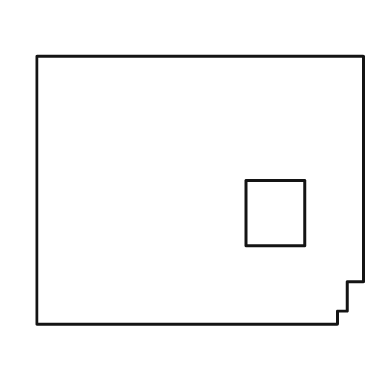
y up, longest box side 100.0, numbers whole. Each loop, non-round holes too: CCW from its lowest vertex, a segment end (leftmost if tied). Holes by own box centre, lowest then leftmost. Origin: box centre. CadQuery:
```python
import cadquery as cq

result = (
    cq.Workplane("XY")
    .moveTo(-50.0, -41.0)
    .lineTo(42.0, -41.0)
    .lineTo(42.0, -37.0)
    .lineTo(45.0, -37.0)
    .lineTo(45.0, -28.0)
    .lineTo(50.0, -28.0)
    .lineTo(50.0, 41.0)
    .lineTo(-50.0, 41.0)
    .close()
    .moveTo(14.0, -17.0)
    .lineTo(32.0, -17.0)
    .lineTo(32.0, 3.0)
    .lineTo(14.0, 3.0)
    .close()
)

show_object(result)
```